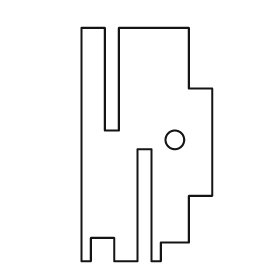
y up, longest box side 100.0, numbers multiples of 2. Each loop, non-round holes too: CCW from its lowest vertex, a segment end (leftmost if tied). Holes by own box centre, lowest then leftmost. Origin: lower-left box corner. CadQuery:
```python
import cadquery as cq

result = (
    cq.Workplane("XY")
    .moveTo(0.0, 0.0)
    .lineTo(4.0, 0.0)
    .lineTo(4.0, 10.0)
    .lineTo(14.0, 10.0)
    .lineTo(14.0, 0.0)
    .lineTo(24.0, 0.0)
    .lineTo(24.0, 48.0)
    .lineTo(30.0, 48.0)
    .lineTo(30.0, 0.0)
    .lineTo(34.0, 0.0)
    .lineTo(34.0, 8.0)
    .lineTo(46.0, 8.0)
    .lineTo(46.0, 28.0)
    .lineTo(56.0, 28.0)
    .lineTo(56.0, 74.0)
    .lineTo(46.0, 74.0)
    .lineTo(46.0, 100.0)
    .lineTo(16.0, 100.0)
    .lineTo(16.0, 56.0)
    .lineTo(10.0, 56.0)
    .lineTo(10.0, 100.0)
    .lineTo(0.0, 100.0)
    .close()
    .moveTo(40.0, 52.0)
    .circle(4.0)
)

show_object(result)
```